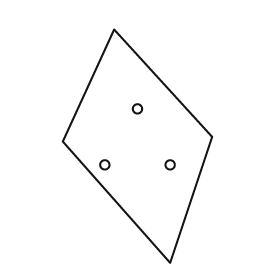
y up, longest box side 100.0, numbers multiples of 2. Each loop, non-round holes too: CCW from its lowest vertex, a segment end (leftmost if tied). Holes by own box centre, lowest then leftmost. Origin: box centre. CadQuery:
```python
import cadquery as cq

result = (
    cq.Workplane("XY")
    .moveTo(14.0, -50.0)
    .lineTo(32.0, 4.0)
    .lineTo(-10.0, 50.0)
    .lineTo(-32.0, 2.0)
    .close()
    .moveTo(-14.0, -8.0)
    .circle(2.0)
    .moveTo(14.0, -8.0)
    .circle(2.0)
    .moveTo(0.0, 16.0)
    .circle(2.0)
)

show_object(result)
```